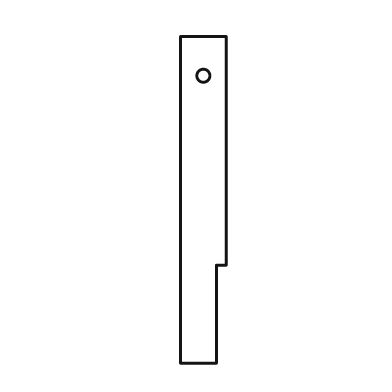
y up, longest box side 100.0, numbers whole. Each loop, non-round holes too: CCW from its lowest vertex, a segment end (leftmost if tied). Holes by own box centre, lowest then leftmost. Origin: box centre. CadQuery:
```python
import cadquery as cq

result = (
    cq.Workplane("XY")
    .moveTo(-7.0, -50.0)
    .lineTo(4.0, -50.0)
    .lineTo(4.0, -20.0)
    .lineTo(7.0, -20.0)
    .lineTo(7.0, 50.0)
    .lineTo(-7.0, 50.0)
    .close()
    .moveTo(0.0, 38.0)
    .circle(2.0)
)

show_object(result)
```